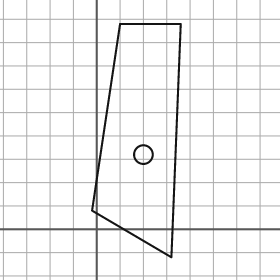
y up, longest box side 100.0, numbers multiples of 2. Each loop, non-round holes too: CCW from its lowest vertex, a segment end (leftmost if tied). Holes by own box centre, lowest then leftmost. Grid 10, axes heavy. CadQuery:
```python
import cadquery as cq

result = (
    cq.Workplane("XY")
    .moveTo(32.0, -12.0)
    .lineTo(36.0, 88.0)
    .lineTo(10.0, 88.0)
    .lineTo(-2.0, 8.0)
    .close()
    .moveTo(20.0, 32.0)
    .circle(4.0)
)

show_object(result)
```